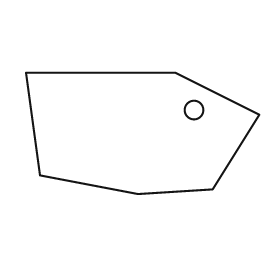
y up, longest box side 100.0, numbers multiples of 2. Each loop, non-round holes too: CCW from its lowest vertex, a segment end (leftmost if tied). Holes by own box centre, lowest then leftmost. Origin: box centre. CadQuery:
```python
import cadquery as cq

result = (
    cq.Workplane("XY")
    .moveTo(-2.0, -26.0)
    .lineTo(30.0, -24.0)
    .lineTo(50.0, 8.0)
    .lineTo(14.0, 26.0)
    .lineTo(-50.0, 26.0)
    .lineTo(-44.0, -18.0)
    .close()
    .moveTo(22.0, 10.0)
    .circle(4.0)
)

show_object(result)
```